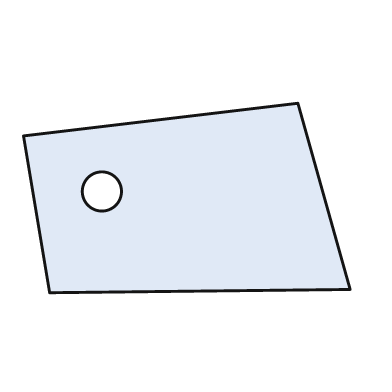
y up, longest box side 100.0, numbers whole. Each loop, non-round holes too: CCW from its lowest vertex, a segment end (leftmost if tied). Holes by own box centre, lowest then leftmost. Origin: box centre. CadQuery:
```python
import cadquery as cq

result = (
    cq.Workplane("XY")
    .moveTo(-42.0, -29.0)
    .lineTo(50.0, -28.0)
    .lineTo(34.0, 29.0)
    .lineTo(-50.0, 19.0)
    .close()
    .moveTo(-26.0, 2.0)
    .circle(6.0)
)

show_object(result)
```